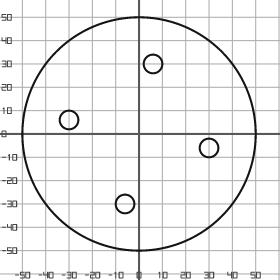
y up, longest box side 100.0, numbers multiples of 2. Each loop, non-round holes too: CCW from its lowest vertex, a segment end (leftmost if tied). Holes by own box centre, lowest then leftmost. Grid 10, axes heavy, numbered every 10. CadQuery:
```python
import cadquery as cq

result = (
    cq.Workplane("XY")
    .moveTo(0.0, 0.0)
    .circle(50.0)
    .moveTo(-6.0, -30.0)
    .circle(4.0)
    .moveTo(30.0, -6.0)
    .circle(4.0)
    .moveTo(-30.0, 6.0)
    .circle(4.0)
    .moveTo(6.0, 30.0)
    .circle(4.0)
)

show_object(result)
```